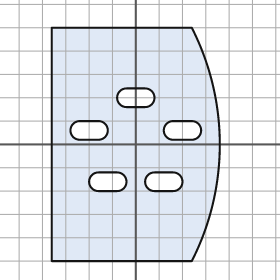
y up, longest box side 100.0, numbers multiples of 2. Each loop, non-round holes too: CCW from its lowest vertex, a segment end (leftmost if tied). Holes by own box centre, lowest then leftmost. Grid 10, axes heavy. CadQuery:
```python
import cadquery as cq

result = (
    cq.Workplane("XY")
    .moveTo(-36.0, -50.0)
    .lineTo(24.0, -50.0)
    .threePointArc((36.0, 0.0), (24.0, 50.0))
    .lineTo(-36.0, 50.0)
    .close()
    .moveTo(-16.0, -20.0)
    .lineTo(-8.0, -20.0)
    .threePointArc((-4.0, -16.0), (-8.0, -12.0))
    .lineTo(-16.0, -12.0)
    .threePointArc((-20.0, -16.0), (-16.0, -20.0))
    .close()
    .moveTo(8.0, -20.0)
    .lineTo(16.0, -20.0)
    .threePointArc((20.0, -16.0), (16.0, -12.0))
    .lineTo(8.0, -12.0)
    .threePointArc((4.0, -16.0), (8.0, -20.0))
    .close()
    .moveTo(-24.0, 2.0)
    .lineTo(-16.0, 2.0)
    .threePointArc((-12.0, 6.0), (-16.0, 10.0))
    .lineTo(-24.0, 10.0)
    .threePointArc((-28.0, 6.0), (-24.0, 2.0))
    .close()
    .moveTo(16.0, 2.0)
    .lineTo(24.0, 2.0)
    .threePointArc((28.0, 6.0), (24.0, 10.0))
    .lineTo(16.0, 10.0)
    .threePointArc((12.0, 6.0), (16.0, 2.0))
    .close()
    .moveTo(-4.0, 16.0)
    .lineTo(4.0, 16.0)
    .threePointArc((8.0, 20.0), (4.0, 24.0))
    .lineTo(-4.0, 24.0)
    .threePointArc((-8.0, 20.0), (-4.0, 16.0))
    .close()
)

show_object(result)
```